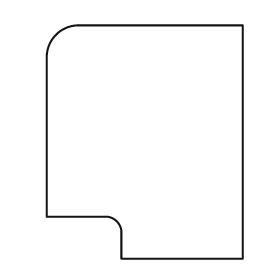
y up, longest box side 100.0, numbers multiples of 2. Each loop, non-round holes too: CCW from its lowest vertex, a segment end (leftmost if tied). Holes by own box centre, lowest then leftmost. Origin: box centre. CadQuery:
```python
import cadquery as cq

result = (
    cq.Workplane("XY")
    .moveTo(-10.0, -50.0)
    .lineTo(42.0, -50.0)
    .lineTo(42.0, 50.0)
    .lineTo(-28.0, 50.0)
    .threePointArc((-38.0, 46.0), (-42.0, 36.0))
    .lineTo(-42.0, -32.0)
    .lineTo(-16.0, -32.0)
    .threePointArc((-12.0, -34.0), (-10.0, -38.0))
    .close()
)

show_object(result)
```